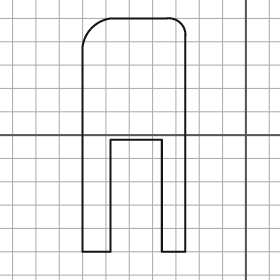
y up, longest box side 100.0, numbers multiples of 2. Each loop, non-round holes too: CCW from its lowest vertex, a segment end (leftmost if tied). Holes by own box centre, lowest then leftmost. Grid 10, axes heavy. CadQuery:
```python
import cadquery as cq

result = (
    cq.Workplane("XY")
    .moveTo(-70.0, -50.0)
    .lineTo(-58.0, -50.0)
    .lineTo(-58.0, -2.0)
    .lineTo(-36.0, -2.0)
    .lineTo(-36.0, -50.0)
    .lineTo(-26.0, -50.0)
    .lineTo(-26.0, 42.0)
    .threePointArc((-28.0, 48.0), (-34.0, 50.0))
    .lineTo(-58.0, 50.0)
    .threePointArc((-66.0, 46.0), (-70.0, 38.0))
    .close()
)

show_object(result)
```